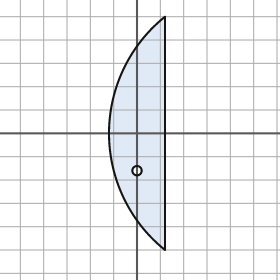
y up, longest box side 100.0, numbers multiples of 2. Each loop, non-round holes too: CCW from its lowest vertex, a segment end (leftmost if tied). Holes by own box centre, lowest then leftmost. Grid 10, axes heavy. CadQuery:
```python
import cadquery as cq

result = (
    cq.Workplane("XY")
    .moveTo(12.0, -50.0)
    .lineTo(12.0, 50.0)
    .threePointArc((-12.0, 0.0), (12.0, -50.0))
    .close()
    .moveTo(0.0, -16.0)
    .circle(2.0)
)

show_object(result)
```